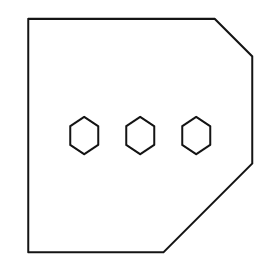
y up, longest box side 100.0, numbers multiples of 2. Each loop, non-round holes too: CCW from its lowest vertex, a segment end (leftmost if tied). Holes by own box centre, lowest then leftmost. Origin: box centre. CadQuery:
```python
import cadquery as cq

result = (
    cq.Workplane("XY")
    .moveTo(-48.0, -50.0)
    .lineTo(10.0, -50.0)
    .lineTo(48.0, -12.0)
    .lineTo(48.0, 34.0)
    .lineTo(32.0, 50.0)
    .lineTo(-48.0, 50.0)
    .close()
    .moveTo(-24.0, -8.0)
    .lineTo(-18.0, -4.0)
    .lineTo(-18.0, 4.0)
    .lineTo(-24.0, 8.0)
    .lineTo(-30.0, 4.0)
    .lineTo(-30.0, -4.0)
    .close()
    .moveTo(0.0, -8.0)
    .lineTo(6.0, -4.0)
    .lineTo(6.0, 4.0)
    .lineTo(0.0, 8.0)
    .lineTo(-6.0, 4.0)
    .lineTo(-6.0, -4.0)
    .close()
    .moveTo(24.0, -8.0)
    .lineTo(30.0, -4.0)
    .lineTo(30.0, 4.0)
    .lineTo(24.0, 8.0)
    .lineTo(18.0, 4.0)
    .lineTo(18.0, -4.0)
    .close()
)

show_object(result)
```